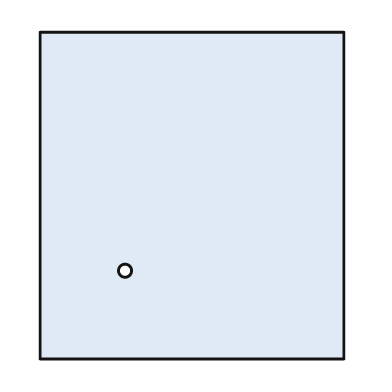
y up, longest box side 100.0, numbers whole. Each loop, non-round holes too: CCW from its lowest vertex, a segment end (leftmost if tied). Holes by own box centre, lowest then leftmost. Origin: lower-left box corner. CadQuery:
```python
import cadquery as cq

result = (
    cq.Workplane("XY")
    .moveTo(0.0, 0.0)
    .lineTo(93.0, 0.0)
    .lineTo(93.0, 100.0)
    .lineTo(0.0, 100.0)
    .close()
    .moveTo(26.0, 27.0)
    .circle(2.0)
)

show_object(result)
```